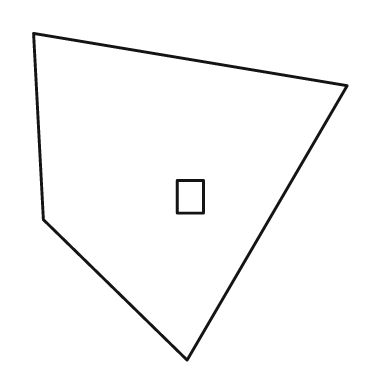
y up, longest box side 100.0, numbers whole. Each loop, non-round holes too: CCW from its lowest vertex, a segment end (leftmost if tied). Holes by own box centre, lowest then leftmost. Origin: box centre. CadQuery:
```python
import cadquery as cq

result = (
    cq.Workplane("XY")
    .moveTo(-1.0, -50.0)
    .lineTo(48.0, 34.0)
    .lineTo(-48.0, 50.0)
    .lineTo(-45.0, -7.0)
    .close()
    .moveTo(-4.0, -5.0)
    .lineTo(4.0, -5.0)
    .lineTo(4.0, 5.0)
    .lineTo(-4.0, 5.0)
    .close()
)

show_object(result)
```